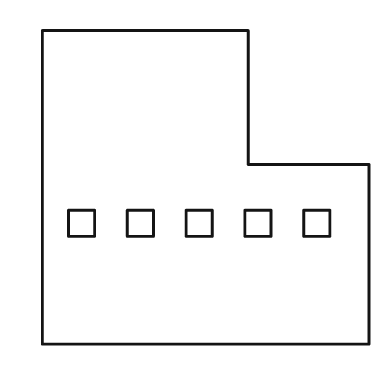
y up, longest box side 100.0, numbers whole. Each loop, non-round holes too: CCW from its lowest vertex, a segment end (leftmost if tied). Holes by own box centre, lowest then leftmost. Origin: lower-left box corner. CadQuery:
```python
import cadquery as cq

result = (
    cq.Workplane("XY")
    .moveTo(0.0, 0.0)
    .lineTo(100.0, 0.0)
    .lineTo(100.0, 55.0)
    .lineTo(63.0, 55.0)
    .lineTo(63.0, 96.0)
    .lineTo(0.0, 96.0)
    .close()
    .moveTo(8.0, 33.0)
    .lineTo(16.0, 33.0)
    .lineTo(16.0, 41.0)
    .lineTo(8.0, 41.0)
    .close()
    .moveTo(26.0, 33.0)
    .lineTo(34.0, 33.0)
    .lineTo(34.0, 41.0)
    .lineTo(26.0, 41.0)
    .close()
    .moveTo(44.0, 33.0)
    .lineTo(52.0, 33.0)
    .lineTo(52.0, 41.0)
    .lineTo(44.0, 41.0)
    .close()
    .moveTo(62.0, 33.0)
    .lineTo(70.0, 33.0)
    .lineTo(70.0, 41.0)
    .lineTo(62.0, 41.0)
    .close()
    .moveTo(80.0, 33.0)
    .lineTo(88.0, 33.0)
    .lineTo(88.0, 41.0)
    .lineTo(80.0, 41.0)
    .close()
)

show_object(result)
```